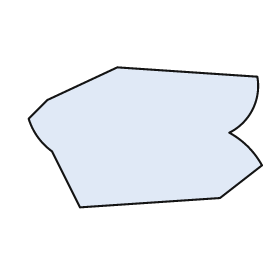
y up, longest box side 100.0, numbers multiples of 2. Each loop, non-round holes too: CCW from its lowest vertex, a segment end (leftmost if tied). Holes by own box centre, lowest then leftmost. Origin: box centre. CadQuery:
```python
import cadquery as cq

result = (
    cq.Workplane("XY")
    .moveTo(-28.0, -30.0)
    .lineTo(32.0, -26.0)
    .lineTo(50.0, -12.0)
    .threePointArc((44.0, -4.0), (36.0, 2.0))
    .threePointArc((46.0, 12.0), (48.0, 26.0))
    .lineTo(-12.0, 30.0)
    .lineTo(-42.0, 16.0)
    .lineTo(-50.0, 8.0)
    .threePointArc((-46.0, 0.0), (-40.0, -6.0))
    .close()
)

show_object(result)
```